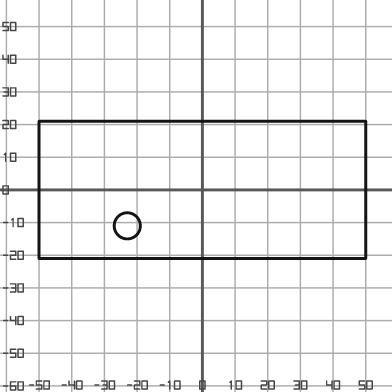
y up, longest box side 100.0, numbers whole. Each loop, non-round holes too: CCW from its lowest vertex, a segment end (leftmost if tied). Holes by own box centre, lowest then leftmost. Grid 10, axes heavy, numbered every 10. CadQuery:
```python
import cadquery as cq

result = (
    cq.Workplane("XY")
    .moveTo(-50.0, -21.0)
    .lineTo(50.0, -21.0)
    .lineTo(50.0, 21.0)
    .lineTo(-50.0, 21.0)
    .close()
    .moveTo(-23.0, -11.0)
    .circle(4.0)
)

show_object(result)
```